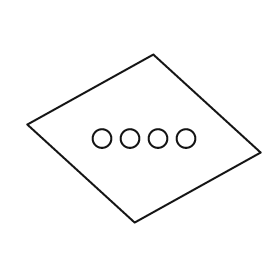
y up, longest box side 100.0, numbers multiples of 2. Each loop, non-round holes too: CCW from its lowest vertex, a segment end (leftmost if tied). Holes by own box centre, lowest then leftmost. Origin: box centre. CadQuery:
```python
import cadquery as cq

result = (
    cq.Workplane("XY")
    .moveTo(-4.0, -36.0)
    .lineTo(50.0, -6.0)
    .lineTo(4.0, 36.0)
    .lineTo(-50.0, 6.0)
    .close()
    .moveTo(-18.0, 0.0)
    .circle(4.0)
    .moveTo(-6.0, 0.0)
    .circle(4.0)
    .moveTo(6.0, 0.0)
    .circle(4.0)
    .moveTo(18.0, 0.0)
    .circle(4.0)
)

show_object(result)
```